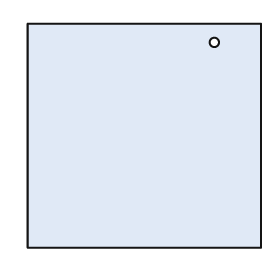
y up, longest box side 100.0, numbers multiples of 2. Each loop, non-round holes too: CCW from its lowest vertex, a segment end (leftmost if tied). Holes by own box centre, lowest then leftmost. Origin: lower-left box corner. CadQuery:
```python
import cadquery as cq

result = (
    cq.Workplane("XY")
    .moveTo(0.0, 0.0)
    .lineTo(100.0, 0.0)
    .lineTo(100.0, 96.0)
    .lineTo(0.0, 96.0)
    .close()
    .moveTo(80.0, 88.0)
    .circle(2.0)
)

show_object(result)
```